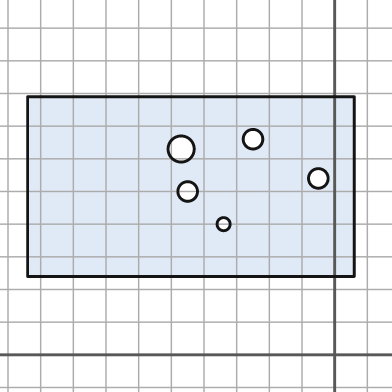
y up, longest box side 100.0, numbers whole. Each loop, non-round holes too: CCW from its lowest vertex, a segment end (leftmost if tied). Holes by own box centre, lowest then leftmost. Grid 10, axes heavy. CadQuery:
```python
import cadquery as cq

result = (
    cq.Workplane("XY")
    .moveTo(-94.0, 24.0)
    .lineTo(6.0, 24.0)
    .lineTo(6.0, 79.0)
    .lineTo(-94.0, 79.0)
    .close()
    .moveTo(-34.0, 40.0)
    .circle(2.0)
    .moveTo(-45.0, 50.0)
    .circle(3.0)
    .moveTo(-5.0, 54.0)
    .circle(3.0)
    .moveTo(-47.0, 63.0)
    .circle(4.0)
    .moveTo(-25.0, 66.0)
    .circle(3.0)
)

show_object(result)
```